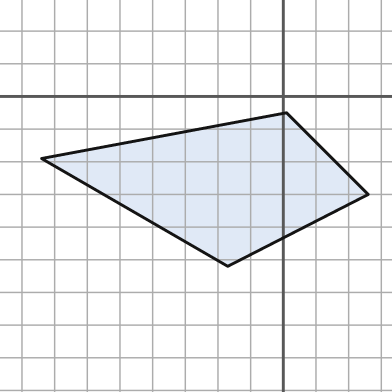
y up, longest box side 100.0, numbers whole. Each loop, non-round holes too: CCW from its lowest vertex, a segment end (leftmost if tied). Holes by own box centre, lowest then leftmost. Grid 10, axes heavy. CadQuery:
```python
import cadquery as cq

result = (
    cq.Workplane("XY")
    .moveTo(-17.0, -52.0)
    .lineTo(26.0, -30.0)
    .lineTo(1.0, -5.0)
    .lineTo(-74.0, -19.0)
    .close()
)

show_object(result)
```